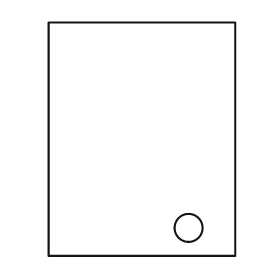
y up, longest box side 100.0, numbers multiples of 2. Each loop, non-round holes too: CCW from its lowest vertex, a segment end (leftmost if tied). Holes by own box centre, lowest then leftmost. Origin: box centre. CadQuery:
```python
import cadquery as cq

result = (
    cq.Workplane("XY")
    .moveTo(-40.0, -50.0)
    .lineTo(40.0, -50.0)
    .lineTo(40.0, 50.0)
    .lineTo(-40.0, 50.0)
    .close()
    .moveTo(20.0, -38.0)
    .circle(6.0)
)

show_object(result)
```